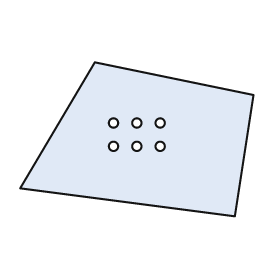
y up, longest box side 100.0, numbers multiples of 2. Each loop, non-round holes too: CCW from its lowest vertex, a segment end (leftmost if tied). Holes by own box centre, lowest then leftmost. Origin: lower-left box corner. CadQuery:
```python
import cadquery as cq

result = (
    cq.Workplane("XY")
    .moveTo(92.0, 0.0)
    .lineTo(100.0, 52.0)
    .lineTo(32.0, 66.0)
    .lineTo(0.0, 12.0)
    .close()
    .moveTo(40.0, 30.0)
    .circle(2.0)
    .moveTo(50.0, 30.0)
    .circle(2.0)
    .moveTo(60.0, 30.0)
    .circle(2.0)
    .moveTo(40.0, 40.0)
    .circle(2.0)
    .moveTo(50.0, 40.0)
    .circle(2.0)
    .moveTo(60.0, 40.0)
    .circle(2.0)
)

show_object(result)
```